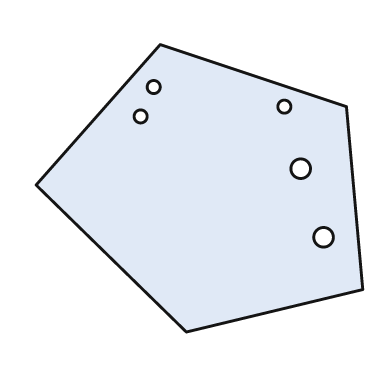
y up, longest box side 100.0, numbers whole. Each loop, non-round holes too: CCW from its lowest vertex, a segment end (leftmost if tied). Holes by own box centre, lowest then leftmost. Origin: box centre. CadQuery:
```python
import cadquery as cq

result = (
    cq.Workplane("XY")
    .moveTo(-4.0, -44.0)
    .lineTo(50.0, -31.0)
    .lineTo(45.0, 25.0)
    .lineTo(-12.0, 44.0)
    .lineTo(-50.0, 1.0)
    .close()
    .moveTo(38.0, -15.0)
    .circle(3.0)
    .moveTo(31.0, 6.0)
    .circle(3.0)
    .moveTo(-18.0, 22.0)
    .circle(2.0)
    .moveTo(26.0, 25.0)
    .circle(2.0)
    .moveTo(-14.0, 31.0)
    .circle(2.0)
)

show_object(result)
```